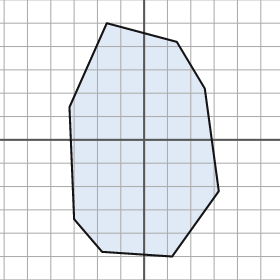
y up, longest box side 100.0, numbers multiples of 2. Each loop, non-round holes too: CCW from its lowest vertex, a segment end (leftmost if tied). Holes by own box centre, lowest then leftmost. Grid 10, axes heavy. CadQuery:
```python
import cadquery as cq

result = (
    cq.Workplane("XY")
    .moveTo(12.0, -50.0)
    .lineTo(32.0, -22.0)
    .lineTo(26.0, 22.0)
    .lineTo(14.0, 42.0)
    .lineTo(-16.0, 50.0)
    .lineTo(-32.0, 14.0)
    .lineTo(-30.0, -34.0)
    .lineTo(-18.0, -48.0)
    .close()
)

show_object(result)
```